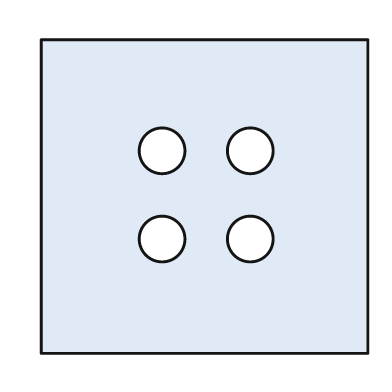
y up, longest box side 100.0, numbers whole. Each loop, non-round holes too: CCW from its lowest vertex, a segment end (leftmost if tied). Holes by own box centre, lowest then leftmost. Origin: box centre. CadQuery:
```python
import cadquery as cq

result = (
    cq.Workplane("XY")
    .moveTo(-50.0, -48.0)
    .lineTo(50.0, -48.0)
    .lineTo(50.0, 48.0)
    .lineTo(-50.0, 48.0)
    .close()
    .moveTo(-13.0, -13.0)
    .circle(7.0)
    .moveTo(14.0, -13.0)
    .circle(7.0)
    .moveTo(-13.0, 14.0)
    .circle(7.0)
    .moveTo(14.0, 14.0)
    .circle(7.0)
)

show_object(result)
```